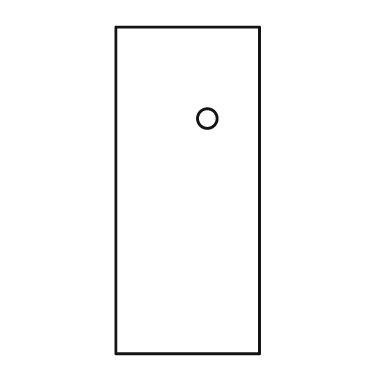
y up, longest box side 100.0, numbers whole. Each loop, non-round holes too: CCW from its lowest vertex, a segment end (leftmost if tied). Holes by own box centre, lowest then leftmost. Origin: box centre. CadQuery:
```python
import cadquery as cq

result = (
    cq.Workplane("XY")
    .moveTo(-22.0, -50.0)
    .lineTo(22.0, -50.0)
    .lineTo(22.0, 50.0)
    .lineTo(-22.0, 50.0)
    .close()
    .moveTo(6.0, 22.0)
    .circle(3.0)
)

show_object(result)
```